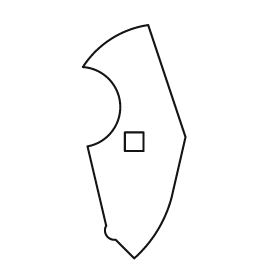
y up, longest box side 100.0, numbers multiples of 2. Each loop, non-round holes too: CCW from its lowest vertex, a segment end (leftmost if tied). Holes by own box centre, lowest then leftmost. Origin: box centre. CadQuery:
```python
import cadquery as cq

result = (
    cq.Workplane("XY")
    .moveTo(0.0, -50.0)
    .threePointArc((10.0, -38.0), (16.0, -24.0))
    .lineTo(22.0, 2.0)
    .lineTo(6.0, 50.0)
    .threePointArc((-10.0, 44.0), (-22.0, 32.0))
    .threePointArc((-6.0, 16.0), (-20.0, -2.0))
    .lineTo(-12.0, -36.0)
    .threePointArc((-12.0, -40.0), (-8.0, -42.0))
    .close()
    .moveTo(-4.0, -4.0)
    .lineTo(4.0, -4.0)
    .lineTo(4.0, 4.0)
    .lineTo(-4.0, 4.0)
    .close()
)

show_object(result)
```